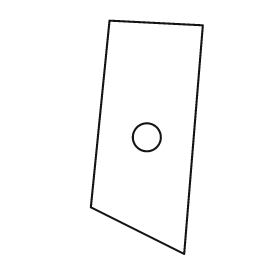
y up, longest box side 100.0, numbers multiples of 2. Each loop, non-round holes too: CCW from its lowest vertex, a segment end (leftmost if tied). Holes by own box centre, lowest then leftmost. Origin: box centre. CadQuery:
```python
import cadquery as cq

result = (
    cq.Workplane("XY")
    .moveTo(16.0, -50.0)
    .lineTo(24.0, 48.0)
    .lineTo(-16.0, 50.0)
    .lineTo(-24.0, -30.0)
    .close()
    .moveTo(0.0, 0.0)
    .circle(6.0)
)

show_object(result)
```